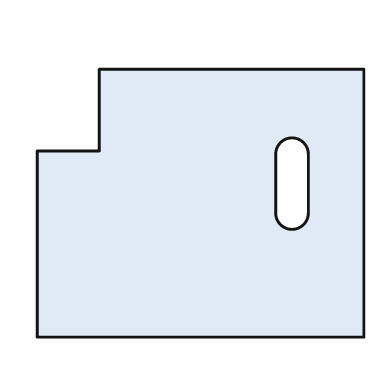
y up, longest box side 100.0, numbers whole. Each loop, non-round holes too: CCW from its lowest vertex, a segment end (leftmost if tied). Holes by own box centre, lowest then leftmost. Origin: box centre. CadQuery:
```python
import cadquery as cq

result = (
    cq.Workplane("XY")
    .moveTo(-50.0, -41.0)
    .lineTo(50.0, -41.0)
    .lineTo(50.0, 41.0)
    .lineTo(-31.0, 41.0)
    .lineTo(-31.0, 16.0)
    .lineTo(-50.0, 16.0)
    .close()
    .moveTo(23.0, -3.0)
    .threePointArc((28.0, -8.0), (33.0, -3.0))
    .lineTo(33.0, 15.0)
    .threePointArc((28.0, 20.0), (23.0, 15.0))
    .close()
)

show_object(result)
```